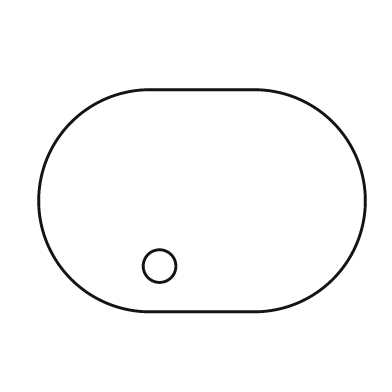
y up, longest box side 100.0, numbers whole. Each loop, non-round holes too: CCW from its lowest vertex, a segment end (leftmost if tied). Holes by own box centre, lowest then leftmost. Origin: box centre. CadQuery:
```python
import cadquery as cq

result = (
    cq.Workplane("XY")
    .moveTo(-16.0, -34.0)
    .lineTo(16.0, -34.0)
    .threePointArc((50.0, 0.0), (16.0, 34.0))
    .lineTo(-16.0, 34.0)
    .threePointArc((-50.0, 0.0), (-16.0, -34.0))
    .close()
    .moveTo(-13.0, -20.0)
    .circle(5.0)
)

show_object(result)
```